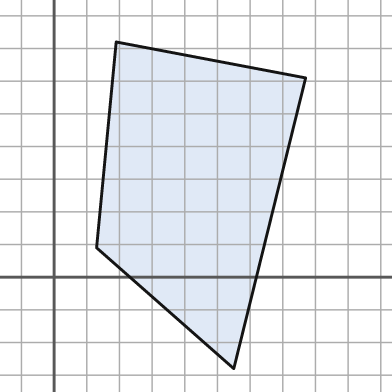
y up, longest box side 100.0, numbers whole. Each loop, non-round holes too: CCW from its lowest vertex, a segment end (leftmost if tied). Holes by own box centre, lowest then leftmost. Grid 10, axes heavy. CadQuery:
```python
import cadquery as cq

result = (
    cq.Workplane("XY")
    .moveTo(55.0, -28.0)
    .lineTo(77.0, 61.0)
    .lineTo(19.0, 72.0)
    .lineTo(13.0, 9.0)
    .close()
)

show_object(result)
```